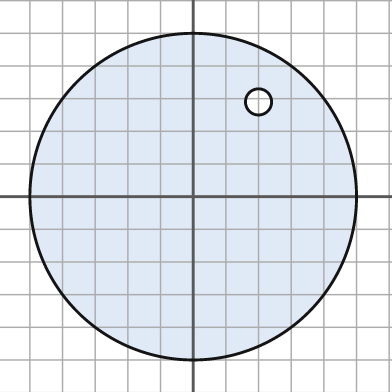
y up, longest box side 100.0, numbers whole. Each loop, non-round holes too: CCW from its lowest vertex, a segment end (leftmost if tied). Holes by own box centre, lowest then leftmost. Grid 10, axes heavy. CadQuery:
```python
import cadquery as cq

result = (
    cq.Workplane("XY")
    .moveTo(0.0, 0.0)
    .circle(50.0)
    .moveTo(20.0, 29.0)
    .circle(4.0)
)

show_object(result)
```